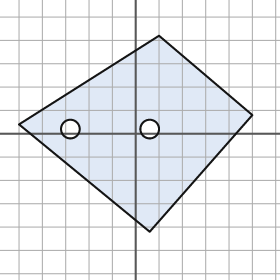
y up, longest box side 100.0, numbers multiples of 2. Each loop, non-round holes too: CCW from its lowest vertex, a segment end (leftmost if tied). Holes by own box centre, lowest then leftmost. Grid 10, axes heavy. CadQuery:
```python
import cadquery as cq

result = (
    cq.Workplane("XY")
    .moveTo(6.0, -42.0)
    .lineTo(50.0, 8.0)
    .lineTo(10.0, 42.0)
    .lineTo(-50.0, 4.0)
    .close()
    .moveTo(-28.0, 2.0)
    .circle(4.0)
    .moveTo(6.0, 2.0)
    .circle(4.0)
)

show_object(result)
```